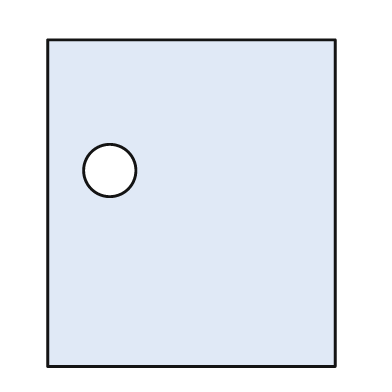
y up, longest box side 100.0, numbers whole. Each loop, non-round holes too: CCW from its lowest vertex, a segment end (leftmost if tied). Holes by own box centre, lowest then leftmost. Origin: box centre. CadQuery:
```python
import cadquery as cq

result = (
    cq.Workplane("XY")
    .moveTo(-44.0, -50.0)
    .lineTo(44.0, -50.0)
    .lineTo(44.0, 50.0)
    .lineTo(-44.0, 50.0)
    .close()
    .moveTo(-25.0, 10.0)
    .circle(8.0)
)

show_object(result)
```